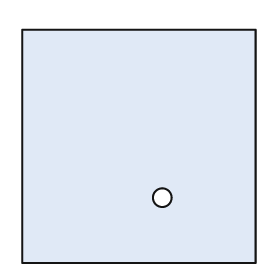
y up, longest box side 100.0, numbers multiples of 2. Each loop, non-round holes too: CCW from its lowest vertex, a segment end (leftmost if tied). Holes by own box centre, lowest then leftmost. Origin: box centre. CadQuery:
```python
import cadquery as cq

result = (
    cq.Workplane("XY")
    .moveTo(-50.0, -50.0)
    .lineTo(50.0, -50.0)
    .lineTo(50.0, 50.0)
    .lineTo(-50.0, 50.0)
    .close()
    .moveTo(10.0, -22.0)
    .circle(4.0)
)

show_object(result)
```